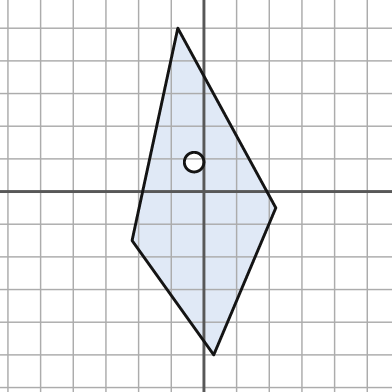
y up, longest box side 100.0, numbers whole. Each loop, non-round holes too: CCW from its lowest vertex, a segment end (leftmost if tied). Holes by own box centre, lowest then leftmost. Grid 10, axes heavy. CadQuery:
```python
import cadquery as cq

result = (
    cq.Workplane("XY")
    .moveTo(3.0, -50.0)
    .lineTo(22.0, -5.0)
    .lineTo(-8.0, 50.0)
    .lineTo(-22.0, -15.0)
    .close()
    .moveTo(-3.0, 9.0)
    .circle(3.0)
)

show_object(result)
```